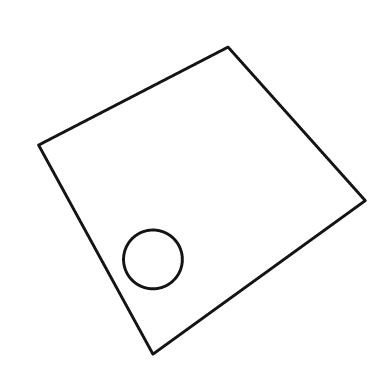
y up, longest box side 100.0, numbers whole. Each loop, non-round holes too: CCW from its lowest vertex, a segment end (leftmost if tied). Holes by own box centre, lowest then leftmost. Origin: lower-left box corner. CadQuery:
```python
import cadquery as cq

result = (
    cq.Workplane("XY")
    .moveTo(35.0, 0.0)
    .lineTo(100.0, 47.0)
    .lineTo(58.0, 94.0)
    .lineTo(0.0, 64.0)
    .close()
    .moveTo(35.0, 29.0)
    .circle(9.0)
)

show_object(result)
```